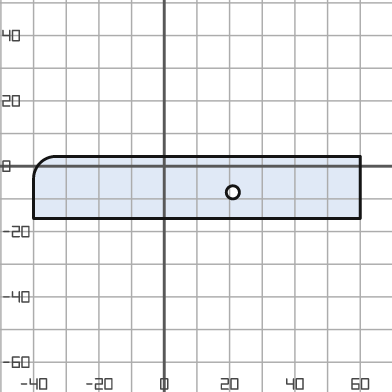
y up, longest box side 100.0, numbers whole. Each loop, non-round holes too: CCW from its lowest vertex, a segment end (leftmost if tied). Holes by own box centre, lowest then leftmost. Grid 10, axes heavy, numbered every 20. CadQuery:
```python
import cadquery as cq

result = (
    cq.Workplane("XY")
    .moveTo(-40.0, -16.0)
    .lineTo(60.0, -16.0)
    .lineTo(60.0, 3.0)
    .lineTo(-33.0, 3.0)
    .threePointArc((-38.0, 1.0), (-40.0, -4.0))
    .close()
    .moveTo(21.0, -8.0)
    .circle(2.0)
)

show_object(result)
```